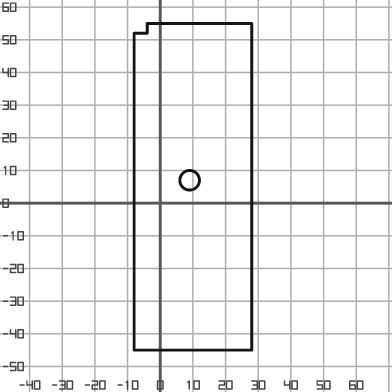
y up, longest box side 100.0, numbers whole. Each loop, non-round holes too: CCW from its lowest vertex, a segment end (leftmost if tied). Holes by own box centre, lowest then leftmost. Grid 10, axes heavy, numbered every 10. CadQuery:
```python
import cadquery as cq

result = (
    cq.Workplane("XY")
    .moveTo(-8.0, -45.0)
    .lineTo(28.0, -45.0)
    .lineTo(28.0, 55.0)
    .lineTo(-4.0, 55.0)
    .lineTo(-4.0, 52.0)
    .lineTo(-8.0, 52.0)
    .close()
    .moveTo(9.0, 7.0)
    .circle(3.0)
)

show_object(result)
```